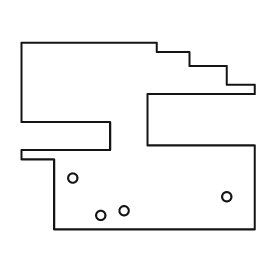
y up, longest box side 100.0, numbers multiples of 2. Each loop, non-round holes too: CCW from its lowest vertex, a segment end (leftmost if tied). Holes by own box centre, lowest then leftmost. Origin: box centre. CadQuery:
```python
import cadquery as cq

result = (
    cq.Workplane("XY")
    .moveTo(-36.0, -40.0)
    .lineTo(50.0, -40.0)
    .lineTo(50.0, -4.0)
    .lineTo(4.0, -4.0)
    .lineTo(4.0, 18.0)
    .lineTo(50.0, 18.0)
    .lineTo(50.0, 22.0)
    .lineTo(38.0, 22.0)
    .lineTo(38.0, 30.0)
    .lineTo(22.0, 30.0)
    .lineTo(22.0, 36.0)
    .lineTo(8.0, 36.0)
    .lineTo(8.0, 40.0)
    .lineTo(-50.0, 40.0)
    .lineTo(-50.0, 6.0)
    .lineTo(-12.0, 6.0)
    .lineTo(-12.0, -6.0)
    .lineTo(-50.0, -6.0)
    .lineTo(-50.0, -10.0)
    .lineTo(-36.0, -10.0)
    .close()
    .moveTo(-16.0, -34.0)
    .circle(2.0)
    .moveTo(-6.0, -32.0)
    .circle(2.0)
    .moveTo(38.0, -26.0)
    .circle(2.0)
    .moveTo(-28.0, -18.0)
    .circle(2.0)
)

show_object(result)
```